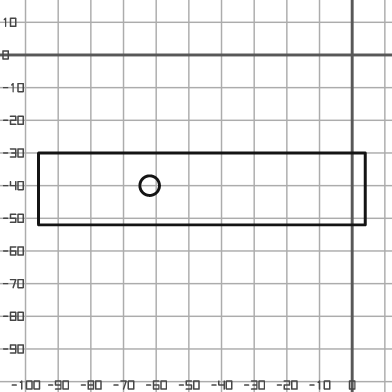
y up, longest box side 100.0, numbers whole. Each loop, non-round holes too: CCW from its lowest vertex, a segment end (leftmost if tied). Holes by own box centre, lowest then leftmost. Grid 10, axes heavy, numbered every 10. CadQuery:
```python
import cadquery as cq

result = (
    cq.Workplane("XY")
    .moveTo(-96.0, -52.0)
    .lineTo(4.0, -52.0)
    .lineTo(4.0, -30.0)
    .lineTo(-96.0, -30.0)
    .close()
    .moveTo(-62.0, -40.0)
    .circle(3.0)
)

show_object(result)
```